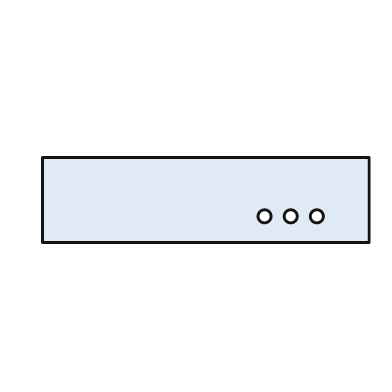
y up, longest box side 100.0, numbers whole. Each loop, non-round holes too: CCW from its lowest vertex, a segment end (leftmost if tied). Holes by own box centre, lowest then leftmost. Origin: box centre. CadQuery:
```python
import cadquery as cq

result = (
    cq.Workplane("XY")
    .moveTo(-50.0, -13.0)
    .lineTo(50.0, -13.0)
    .lineTo(50.0, 13.0)
    .lineTo(-50.0, 13.0)
    .close()
    .moveTo(18.0, -5.0)
    .circle(2.0)
    .moveTo(26.0, -5.0)
    .circle(2.0)
    .moveTo(34.0, -5.0)
    .circle(2.0)
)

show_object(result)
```